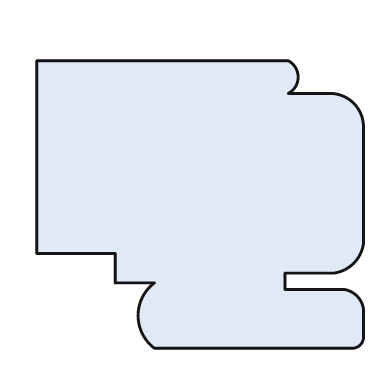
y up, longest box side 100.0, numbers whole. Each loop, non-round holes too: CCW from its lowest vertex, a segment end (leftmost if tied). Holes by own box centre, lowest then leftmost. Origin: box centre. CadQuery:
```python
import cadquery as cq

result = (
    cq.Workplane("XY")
    .moveTo(-14.0, -44.0)
    .lineTo(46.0, -44.0)
    .threePointArc((49.0, -43.0), (50.0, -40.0))
    .lineTo(50.0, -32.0)
    .threePointArc((48.0, -28.0), (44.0, -26.0))
    .lineTo(26.0, -26.0)
    .lineTo(26.0, -21.0)
    .lineTo(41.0, -21.0)
    .threePointArc((47.0, -18.0), (50.0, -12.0))
    .lineTo(50.0, 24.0)
    .threePointArc((47.0, 31.0), (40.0, 34.0))
    .lineTo(27.0, 34.0)
    .threePointArc((30.0, 39.0), (27.0, 44.0))
    .lineTo(-50.0, 44.0)
    .lineTo(-50.0, -15.0)
    .lineTo(-26.0, -15.0)
    .lineTo(-26.0, -24.0)
    .lineTo(-14.0, -24.0)
    .threePointArc((-19.0, -34.0), (-14.0, -44.0))
    .close()
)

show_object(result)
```